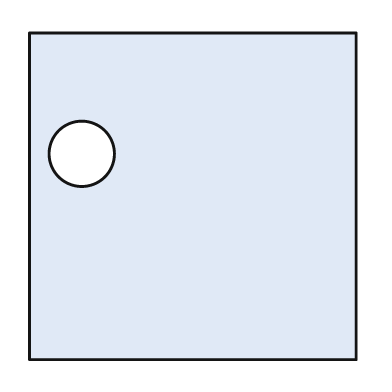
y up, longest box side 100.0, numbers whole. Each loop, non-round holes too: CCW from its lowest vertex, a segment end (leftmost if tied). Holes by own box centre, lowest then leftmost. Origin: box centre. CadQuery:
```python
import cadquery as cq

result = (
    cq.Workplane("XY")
    .moveTo(-50.0, -50.0)
    .lineTo(50.0, -50.0)
    .lineTo(50.0, 50.0)
    .lineTo(-50.0, 50.0)
    .close()
    .moveTo(-34.0, 13.0)
    .circle(10.0)
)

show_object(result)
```